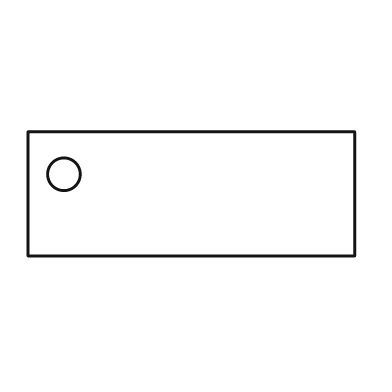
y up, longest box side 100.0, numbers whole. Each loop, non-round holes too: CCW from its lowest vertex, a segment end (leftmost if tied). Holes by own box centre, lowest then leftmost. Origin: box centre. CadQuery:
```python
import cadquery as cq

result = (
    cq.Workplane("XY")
    .moveTo(-50.0, -19.0)
    .lineTo(50.0, -19.0)
    .lineTo(50.0, 19.0)
    .lineTo(-50.0, 19.0)
    .close()
    .moveTo(-39.0, 6.0)
    .circle(5.0)
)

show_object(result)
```